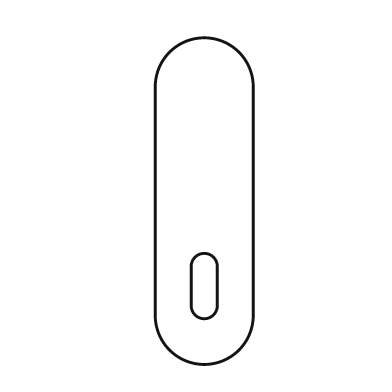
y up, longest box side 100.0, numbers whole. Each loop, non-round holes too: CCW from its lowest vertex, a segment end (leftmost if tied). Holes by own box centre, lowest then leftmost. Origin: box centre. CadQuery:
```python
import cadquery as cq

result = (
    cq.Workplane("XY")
    .moveTo(-15.0, -35.0)
    .threePointArc((0.0, -50.0), (15.0, -35.0))
    .lineTo(15.0, 35.0)
    .threePointArc((0.0, 50.0), (-15.0, 35.0))
    .close()
    .moveTo(-4.0, -32.0)
    .threePointArc((0.0, -36.0), (4.0, -32.0))
    .lineTo(4.0, -20.0)
    .threePointArc((0.0, -16.0), (-4.0, -20.0))
    .close()
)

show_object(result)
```